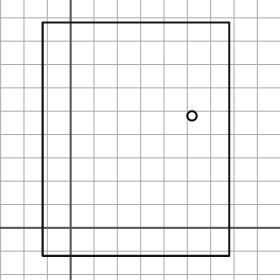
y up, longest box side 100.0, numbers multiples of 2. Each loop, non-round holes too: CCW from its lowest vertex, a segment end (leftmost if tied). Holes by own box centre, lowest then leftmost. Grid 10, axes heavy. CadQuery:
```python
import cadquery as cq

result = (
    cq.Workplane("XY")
    .moveTo(-12.0, -12.0)
    .lineTo(68.0, -12.0)
    .lineTo(68.0, 88.0)
    .lineTo(-12.0, 88.0)
    .close()
    .moveTo(52.0, 48.0)
    .circle(2.0)
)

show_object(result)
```